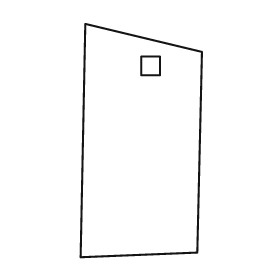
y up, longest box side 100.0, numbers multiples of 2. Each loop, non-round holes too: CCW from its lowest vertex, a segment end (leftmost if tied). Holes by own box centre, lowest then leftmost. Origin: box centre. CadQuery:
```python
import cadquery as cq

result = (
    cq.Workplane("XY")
    .moveTo(-26.0, -50.0)
    .lineTo(24.0, -48.0)
    .lineTo(26.0, 38.0)
    .lineTo(-24.0, 50.0)
    .close()
    .moveTo(0.0, 28.0)
    .lineTo(8.0, 28.0)
    .lineTo(8.0, 36.0)
    .lineTo(0.0, 36.0)
    .close()
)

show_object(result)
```